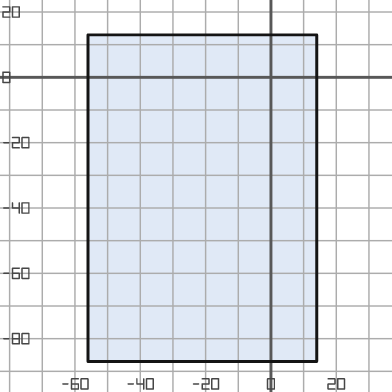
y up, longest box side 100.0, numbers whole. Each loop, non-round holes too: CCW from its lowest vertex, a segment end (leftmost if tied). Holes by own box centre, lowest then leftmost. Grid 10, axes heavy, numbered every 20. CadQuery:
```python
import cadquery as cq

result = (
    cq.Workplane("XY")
    .moveTo(-56.0, -87.0)
    .lineTo(14.0, -87.0)
    .lineTo(14.0, 13.0)
    .lineTo(-56.0, 13.0)
    .close()
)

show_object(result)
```